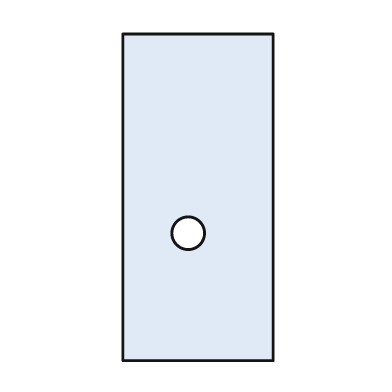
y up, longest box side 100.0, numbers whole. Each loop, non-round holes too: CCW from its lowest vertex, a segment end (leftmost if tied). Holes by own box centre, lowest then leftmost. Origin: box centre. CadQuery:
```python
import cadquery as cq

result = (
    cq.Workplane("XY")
    .moveTo(-23.0, -50.0)
    .lineTo(23.0, -50.0)
    .lineTo(23.0, 50.0)
    .lineTo(-23.0, 50.0)
    .close()
    .moveTo(-3.0, -11.0)
    .circle(5.0)
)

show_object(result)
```